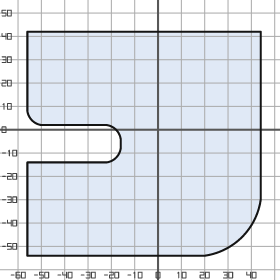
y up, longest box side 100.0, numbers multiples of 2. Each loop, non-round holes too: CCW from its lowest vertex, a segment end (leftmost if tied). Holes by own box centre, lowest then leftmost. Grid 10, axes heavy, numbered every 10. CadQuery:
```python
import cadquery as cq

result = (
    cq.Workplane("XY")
    .moveTo(-56.0, -54.0)
    .lineTo(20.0, -54.0)
    .threePointArc((36.0, -46.0), (44.0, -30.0))
    .lineTo(44.0, 42.0)
    .lineTo(-56.0, 42.0)
    .lineTo(-56.0, 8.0)
    .threePointArc((-54.0, 4.0), (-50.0, 2.0))
    .lineTo(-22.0, 2.0)
    .threePointArc((-18.0, 0.0), (-16.0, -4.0))
    .lineTo(-16.0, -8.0)
    .threePointArc((-18.0, -12.0), (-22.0, -14.0))
    .lineTo(-56.0, -14.0)
    .close()
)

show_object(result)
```